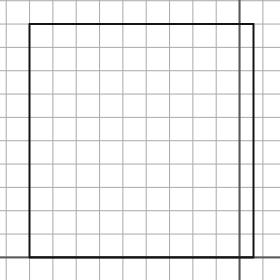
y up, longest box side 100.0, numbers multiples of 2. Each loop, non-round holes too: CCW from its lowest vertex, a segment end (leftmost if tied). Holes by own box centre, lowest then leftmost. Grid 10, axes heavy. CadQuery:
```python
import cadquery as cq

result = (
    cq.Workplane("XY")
    .moveTo(-90.0, 0.0)
    .lineTo(6.0, 0.0)
    .lineTo(6.0, 100.0)
    .lineTo(-90.0, 100.0)
    .close()
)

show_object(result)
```